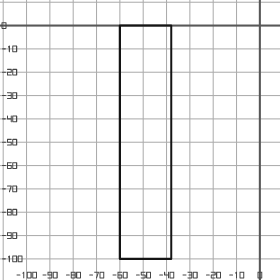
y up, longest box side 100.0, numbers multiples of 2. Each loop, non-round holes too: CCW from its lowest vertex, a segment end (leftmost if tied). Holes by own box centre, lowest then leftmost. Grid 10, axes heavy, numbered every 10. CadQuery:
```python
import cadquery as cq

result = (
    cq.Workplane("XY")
    .moveTo(-60.0, -100.0)
    .lineTo(-38.0, -100.0)
    .lineTo(-38.0, 0.0)
    .lineTo(-60.0, 0.0)
    .close()
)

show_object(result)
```